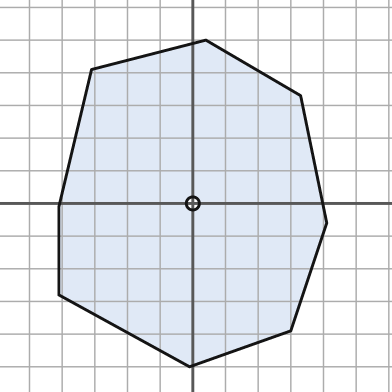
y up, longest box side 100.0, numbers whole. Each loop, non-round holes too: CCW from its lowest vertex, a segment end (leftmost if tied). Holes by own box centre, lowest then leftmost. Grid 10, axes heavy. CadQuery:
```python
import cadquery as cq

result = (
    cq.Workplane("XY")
    .moveTo(-1.0, -50.0)
    .lineTo(30.0, -39.0)
    .lineTo(41.0, -6.0)
    .lineTo(33.0, 33.0)
    .lineTo(4.0, 50.0)
    .lineTo(-31.0, 41.0)
    .lineTo(-41.0, -1.0)
    .lineTo(-41.0, -28.0)
    .close()
    .moveTo(0.0, 0.0)
    .circle(2.0)
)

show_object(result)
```